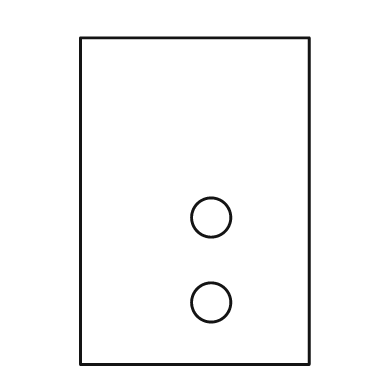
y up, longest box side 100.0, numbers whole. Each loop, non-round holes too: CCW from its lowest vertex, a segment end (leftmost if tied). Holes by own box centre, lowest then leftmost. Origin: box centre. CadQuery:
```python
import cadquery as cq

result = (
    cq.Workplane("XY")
    .moveTo(-35.0, -50.0)
    .lineTo(35.0, -50.0)
    .lineTo(35.0, 50.0)
    .lineTo(-35.0, 50.0)
    .close()
    .moveTo(5.0, -31.0)
    .circle(6.0)
    .moveTo(5.0, -5.0)
    .circle(6.0)
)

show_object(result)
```